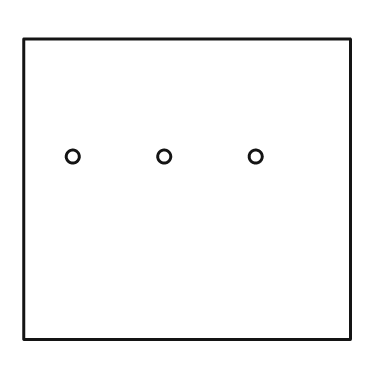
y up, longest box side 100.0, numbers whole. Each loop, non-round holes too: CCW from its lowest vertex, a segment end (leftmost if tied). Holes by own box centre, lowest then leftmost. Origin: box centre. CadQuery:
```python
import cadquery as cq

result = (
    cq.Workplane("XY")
    .moveTo(-50.0, -46.0)
    .lineTo(50.0, -46.0)
    .lineTo(50.0, 46.0)
    .lineTo(-50.0, 46.0)
    .close()
    .moveTo(-35.0, 10.0)
    .circle(2.0)
    .moveTo(-7.0, 10.0)
    .circle(2.0)
    .moveTo(21.0, 10.0)
    .circle(2.0)
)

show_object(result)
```